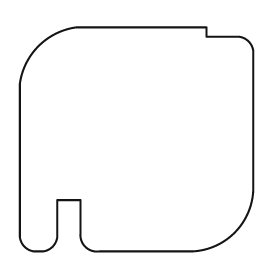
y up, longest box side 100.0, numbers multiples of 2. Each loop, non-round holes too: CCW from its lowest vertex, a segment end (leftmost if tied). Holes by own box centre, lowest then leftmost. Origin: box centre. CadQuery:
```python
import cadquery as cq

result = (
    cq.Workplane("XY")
    .moveTo(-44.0, -48.0)
    .lineTo(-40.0, -48.0)
    .threePointArc((-36.0, -46.0), (-34.0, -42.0))
    .lineTo(-34.0, -26.0)
    .lineTo(-24.0, -26.0)
    .lineTo(-24.0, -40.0)
    .threePointArc((-22.0, -46.0), (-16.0, -48.0))
    .lineTo(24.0, -48.0)
    .threePointArc((42.0, -40.0), (50.0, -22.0))
    .lineTo(50.0, 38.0)
    .threePointArc((48.0, 42.0), (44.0, 44.0))
    .lineTo(30.0, 44.0)
    .lineTo(30.0, 48.0)
    .lineTo(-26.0, 48.0)
    .threePointArc((-42.0, 40.0), (-50.0, 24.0))
    .lineTo(-50.0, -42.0)
    .threePointArc((-48.0, -46.0), (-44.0, -48.0))
    .close()
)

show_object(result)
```